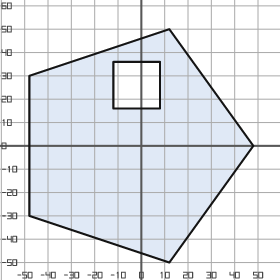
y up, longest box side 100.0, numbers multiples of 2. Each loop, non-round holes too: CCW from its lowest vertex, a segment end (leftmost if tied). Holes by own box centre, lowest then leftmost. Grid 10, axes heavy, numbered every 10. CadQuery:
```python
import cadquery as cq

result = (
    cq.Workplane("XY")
    .moveTo(12.0, -50.0)
    .lineTo(48.0, 0.0)
    .lineTo(12.0, 50.0)
    .lineTo(-48.0, 30.0)
    .lineTo(-48.0, -30.0)
    .close()
    .moveTo(-12.0, 16.0)
    .lineTo(8.0, 16.0)
    .lineTo(8.0, 36.0)
    .lineTo(-12.0, 36.0)
    .close()
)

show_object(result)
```